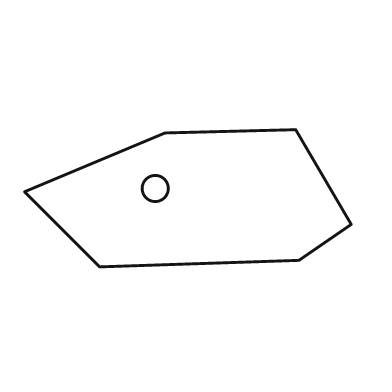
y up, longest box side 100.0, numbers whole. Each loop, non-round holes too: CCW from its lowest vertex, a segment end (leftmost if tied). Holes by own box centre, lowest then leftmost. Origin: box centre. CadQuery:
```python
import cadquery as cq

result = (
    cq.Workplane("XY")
    .moveTo(-27.0, -21.0)
    .lineTo(34.0, -19.0)
    .lineTo(50.0, -8.0)
    .lineTo(33.0, 21.0)
    .lineTo(-7.0, 20.0)
    .lineTo(-50.0, 2.0)
    .close()
    .moveTo(-10.0, 3.0)
    .circle(4.0)
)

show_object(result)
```